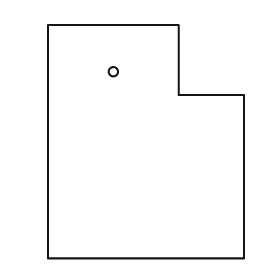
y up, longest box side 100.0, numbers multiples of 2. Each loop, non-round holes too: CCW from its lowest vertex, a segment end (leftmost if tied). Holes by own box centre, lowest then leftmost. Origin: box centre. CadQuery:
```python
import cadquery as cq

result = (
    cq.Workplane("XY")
    .moveTo(-42.0, -50.0)
    .lineTo(42.0, -50.0)
    .lineTo(42.0, 20.0)
    .lineTo(14.0, 20.0)
    .lineTo(14.0, 50.0)
    .lineTo(-42.0, 50.0)
    .close()
    .moveTo(-14.0, 30.0)
    .circle(2.0)
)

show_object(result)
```